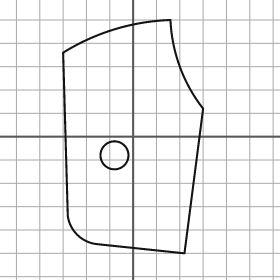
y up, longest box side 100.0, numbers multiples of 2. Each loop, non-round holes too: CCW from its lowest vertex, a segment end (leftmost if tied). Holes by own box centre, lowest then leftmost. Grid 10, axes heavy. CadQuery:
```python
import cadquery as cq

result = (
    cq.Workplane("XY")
    .moveTo(22.0, -50.0)
    .lineTo(30.0, 12.0)
    .threePointArc((20.0, 30.0), (16.0, 50.0))
    .threePointArc((-8.0, 46.0), (-30.0, 36.0))
    .lineTo(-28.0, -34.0)
    .threePointArc((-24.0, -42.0), (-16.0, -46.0))
    .close()
    .moveTo(-8.0, -8.0)
    .circle(6.0)
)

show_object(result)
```